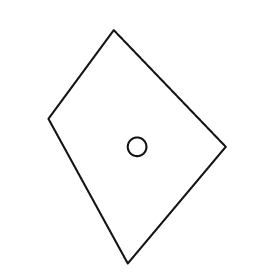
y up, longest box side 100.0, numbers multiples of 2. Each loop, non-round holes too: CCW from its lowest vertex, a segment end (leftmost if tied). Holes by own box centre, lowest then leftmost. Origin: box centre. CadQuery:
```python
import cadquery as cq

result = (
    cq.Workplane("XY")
    .moveTo(-4.0, -50.0)
    .lineTo(38.0, 0.0)
    .lineTo(-10.0, 50.0)
    .lineTo(-38.0, 12.0)
    .close()
    .moveTo(0.0, 0.0)
    .circle(4.0)
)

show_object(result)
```